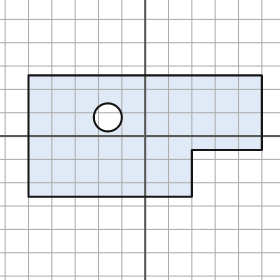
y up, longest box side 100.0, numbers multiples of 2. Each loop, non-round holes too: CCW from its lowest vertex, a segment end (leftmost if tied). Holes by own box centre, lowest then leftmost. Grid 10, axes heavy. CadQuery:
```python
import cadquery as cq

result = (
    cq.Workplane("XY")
    .moveTo(-50.0, -26.0)
    .lineTo(20.0, -26.0)
    .lineTo(20.0, -6.0)
    .lineTo(50.0, -6.0)
    .lineTo(50.0, 26.0)
    .lineTo(-50.0, 26.0)
    .close()
    .moveTo(-16.0, 8.0)
    .circle(6.0)
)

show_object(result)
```